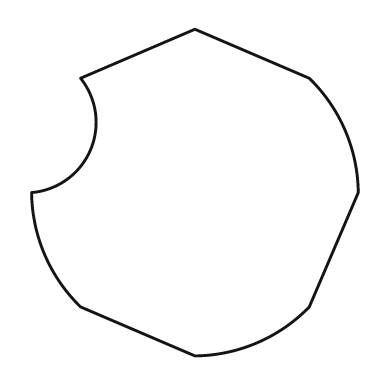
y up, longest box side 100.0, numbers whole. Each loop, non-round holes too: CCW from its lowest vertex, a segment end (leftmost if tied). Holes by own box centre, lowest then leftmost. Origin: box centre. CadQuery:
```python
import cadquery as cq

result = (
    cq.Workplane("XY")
    .moveTo(0.0, -50.0)
    .threePointArc((19.0, -46.0), (35.0, -35.0))
    .lineTo(50.0, 0.0)
    .threePointArc((46.0, 19.0), (35.0, 35.0))
    .lineTo(0.0, 50.0)
    .lineTo(-35.0, 35.0)
    .threePointArc((-32.0, 13.0), (-50.0, 0.0))
    .threePointArc((-46.0, -19.0), (-35.0, -35.0))
    .close()
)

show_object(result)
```